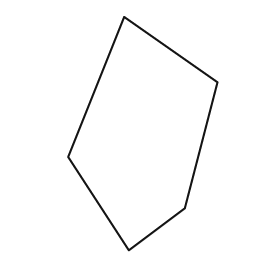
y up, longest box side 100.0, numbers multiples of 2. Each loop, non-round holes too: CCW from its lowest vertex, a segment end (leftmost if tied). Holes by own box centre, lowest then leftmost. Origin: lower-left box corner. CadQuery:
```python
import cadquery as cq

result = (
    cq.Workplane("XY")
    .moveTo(26.0, 0.0)
    .lineTo(50.0, 18.0)
    .lineTo(64.0, 72.0)
    .lineTo(24.0, 100.0)
    .lineTo(0.0, 40.0)
    .close()
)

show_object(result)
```